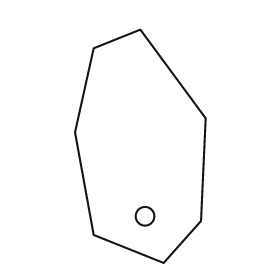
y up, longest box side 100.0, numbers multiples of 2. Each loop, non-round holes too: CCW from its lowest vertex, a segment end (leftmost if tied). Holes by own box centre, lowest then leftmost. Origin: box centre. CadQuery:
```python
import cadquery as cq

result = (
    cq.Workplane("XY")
    .moveTo(10.0, -50.0)
    .lineTo(26.0, -32.0)
    .lineTo(28.0, 12.0)
    .lineTo(0.0, 50.0)
    .lineTo(-20.0, 42.0)
    .lineTo(-28.0, 6.0)
    .lineTo(-20.0, -38.0)
    .close()
    .moveTo(2.0, -30.0)
    .circle(4.0)
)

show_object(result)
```